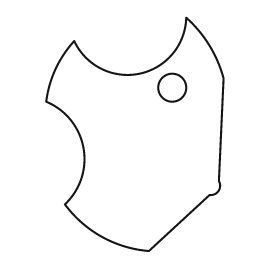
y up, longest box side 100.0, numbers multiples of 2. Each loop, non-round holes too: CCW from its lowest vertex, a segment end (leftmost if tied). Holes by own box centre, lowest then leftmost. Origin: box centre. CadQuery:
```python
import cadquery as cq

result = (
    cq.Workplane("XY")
    .moveTo(6.0, -50.0)
    .lineTo(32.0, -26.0)
    .threePointArc((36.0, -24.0), (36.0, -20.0))
    .lineTo(38.0, 24.0)
    .threePointArc((32.0, 38.0), (22.0, 50.0))
    .threePointArc((2.0, 26.0), (-26.0, 40.0))
    .threePointArc((-34.0, 28.0), (-38.0, 14.0))
    .threePointArc((-22.0, -6.0), (-30.0, -30.0))
    .threePointArc((-14.0, -44.0), (6.0, -50.0))
    .close()
    .moveTo(16.0, 20.0)
    .circle(6.0)
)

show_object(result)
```